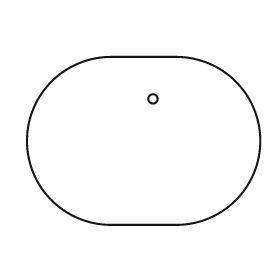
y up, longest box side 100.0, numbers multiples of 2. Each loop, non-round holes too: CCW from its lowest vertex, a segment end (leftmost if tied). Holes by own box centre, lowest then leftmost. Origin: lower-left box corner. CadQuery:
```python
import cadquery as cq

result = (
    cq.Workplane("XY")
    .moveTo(36.0, 0.0)
    .lineTo(64.0, 0.0)
    .threePointArc((100.0, 36.0), (64.0, 72.0))
    .lineTo(36.0, 72.0)
    .threePointArc((0.0, 36.0), (36.0, 0.0))
    .close()
    .moveTo(54.0, 54.0)
    .circle(2.0)
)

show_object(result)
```